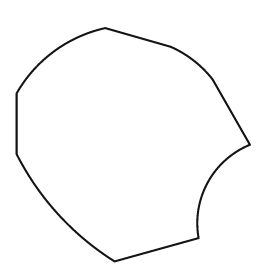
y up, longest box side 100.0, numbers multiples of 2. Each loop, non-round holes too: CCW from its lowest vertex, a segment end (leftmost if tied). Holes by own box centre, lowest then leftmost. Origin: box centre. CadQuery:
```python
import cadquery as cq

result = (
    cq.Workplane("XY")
    .moveTo(-8.0, -50.0)
    .lineTo(28.0, -40.0)
    .threePointArc((32.0, -16.0), (50.0, 0.0))
    .lineTo(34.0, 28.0)
    .threePointArc((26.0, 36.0), (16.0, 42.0))
    .lineTo(-12.0, 50.0)
    .threePointArc((-34.0, 40.0), (-50.0, 22.0))
    .lineTo(-50.0, -4.0)
    .threePointArc((-32.0, -30.0), (-8.0, -50.0))
    .close()
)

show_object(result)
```